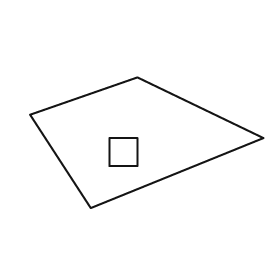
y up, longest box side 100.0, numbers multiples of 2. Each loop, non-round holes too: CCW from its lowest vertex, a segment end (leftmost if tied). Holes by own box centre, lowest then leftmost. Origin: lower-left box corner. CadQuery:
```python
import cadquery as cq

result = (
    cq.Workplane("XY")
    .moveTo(26.0, 0.0)
    .lineTo(100.0, 30.0)
    .lineTo(46.0, 56.0)
    .lineTo(0.0, 40.0)
    .close()
    .moveTo(34.0, 18.0)
    .lineTo(46.0, 18.0)
    .lineTo(46.0, 30.0)
    .lineTo(34.0, 30.0)
    .close()
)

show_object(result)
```